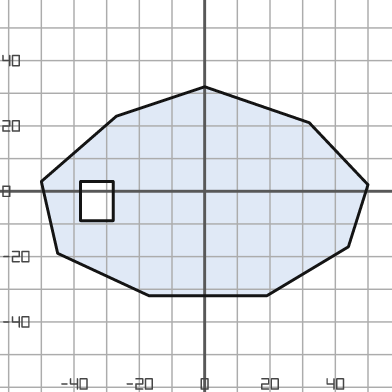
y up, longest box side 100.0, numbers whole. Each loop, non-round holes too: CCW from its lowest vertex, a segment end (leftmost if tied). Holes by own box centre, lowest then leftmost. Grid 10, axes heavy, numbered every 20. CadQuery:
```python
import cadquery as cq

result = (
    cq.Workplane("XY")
    .moveTo(-17.0, -32.0)
    .lineTo(19.0, -32.0)
    .lineTo(44.0, -17.0)
    .lineTo(50.0, 2.0)
    .lineTo(32.0, 21.0)
    .lineTo(0.0, 32.0)
    .lineTo(-27.0, 23.0)
    .lineTo(-50.0, 3.0)
    .lineTo(-45.0, -19.0)
    .close()
    .moveTo(-38.0, -9.0)
    .lineTo(-28.0, -9.0)
    .lineTo(-28.0, 3.0)
    .lineTo(-38.0, 3.0)
    .close()
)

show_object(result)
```